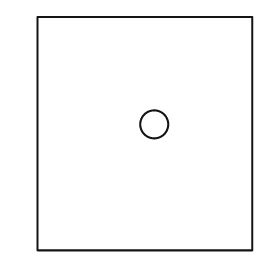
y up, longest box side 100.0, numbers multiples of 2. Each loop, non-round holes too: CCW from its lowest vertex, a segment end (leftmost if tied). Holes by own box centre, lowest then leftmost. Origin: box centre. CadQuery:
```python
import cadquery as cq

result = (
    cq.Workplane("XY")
    .moveTo(-46.0, -50.0)
    .lineTo(46.0, -50.0)
    .lineTo(46.0, 50.0)
    .lineTo(-46.0, 50.0)
    .close()
    .moveTo(4.0, 4.0)
    .circle(6.0)
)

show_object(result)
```